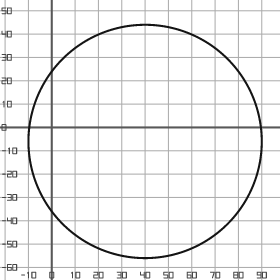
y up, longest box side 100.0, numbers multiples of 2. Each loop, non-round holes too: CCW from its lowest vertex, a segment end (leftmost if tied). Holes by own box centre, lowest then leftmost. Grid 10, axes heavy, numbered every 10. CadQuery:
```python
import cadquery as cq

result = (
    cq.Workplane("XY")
    .moveTo(40.0, -6.0)
    .circle(50.0)
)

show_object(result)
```